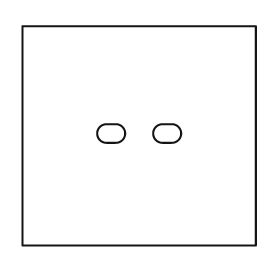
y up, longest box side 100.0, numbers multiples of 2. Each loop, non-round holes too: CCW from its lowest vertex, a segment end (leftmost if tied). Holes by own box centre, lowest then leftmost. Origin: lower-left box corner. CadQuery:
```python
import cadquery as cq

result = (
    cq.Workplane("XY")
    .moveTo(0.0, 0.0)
    .lineTo(100.0, 0.0)
    .lineTo(100.0, 94.0)
    .lineTo(0.0, 94.0)
    .close()
    .moveTo(36.0, 44.0)
    .lineTo(40.0, 44.0)
    .threePointArc((44.0, 48.0), (40.0, 52.0))
    .lineTo(36.0, 52.0)
    .threePointArc((32.0, 48.0), (36.0, 44.0))
    .close()
    .moveTo(60.0, 44.0)
    .lineTo(64.0, 44.0)
    .threePointArc((68.0, 48.0), (64.0, 52.0))
    .lineTo(60.0, 52.0)
    .threePointArc((56.0, 48.0), (60.0, 44.0))
    .close()
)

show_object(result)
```